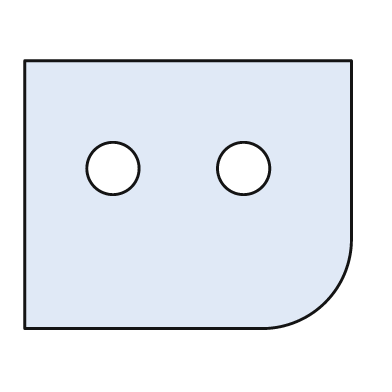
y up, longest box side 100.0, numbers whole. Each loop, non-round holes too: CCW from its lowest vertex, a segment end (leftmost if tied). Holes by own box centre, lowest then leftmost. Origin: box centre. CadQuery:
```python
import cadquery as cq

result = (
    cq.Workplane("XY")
    .moveTo(-50.0, -41.0)
    .lineTo(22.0, -41.0)
    .threePointArc((42.0, -33.0), (50.0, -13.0))
    .lineTo(50.0, 41.0)
    .lineTo(-50.0, 41.0)
    .close()
    .moveTo(-23.0, 8.0)
    .circle(8.0)
    .moveTo(17.0, 8.0)
    .circle(8.0)
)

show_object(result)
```